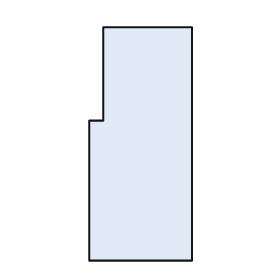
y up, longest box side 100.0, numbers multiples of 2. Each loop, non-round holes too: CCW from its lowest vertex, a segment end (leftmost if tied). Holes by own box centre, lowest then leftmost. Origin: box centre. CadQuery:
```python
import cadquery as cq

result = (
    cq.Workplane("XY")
    .moveTo(-22.0, -50.0)
    .lineTo(22.0, -50.0)
    .lineTo(22.0, 50.0)
    .lineTo(-16.0, 50.0)
    .lineTo(-16.0, 10.0)
    .lineTo(-22.0, 10.0)
    .close()
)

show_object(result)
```